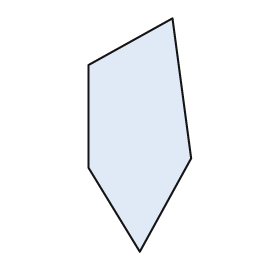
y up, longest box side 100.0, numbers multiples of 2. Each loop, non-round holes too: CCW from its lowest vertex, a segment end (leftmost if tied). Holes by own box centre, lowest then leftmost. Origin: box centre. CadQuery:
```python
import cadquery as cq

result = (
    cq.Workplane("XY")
    .moveTo(0.0, -50.0)
    .lineTo(22.0, -10.0)
    .lineTo(14.0, 50.0)
    .lineTo(-22.0, 30.0)
    .lineTo(-22.0, -14.0)
    .close()
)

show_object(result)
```